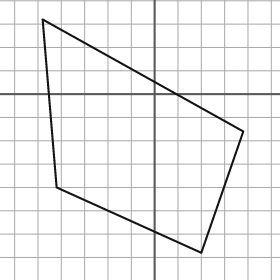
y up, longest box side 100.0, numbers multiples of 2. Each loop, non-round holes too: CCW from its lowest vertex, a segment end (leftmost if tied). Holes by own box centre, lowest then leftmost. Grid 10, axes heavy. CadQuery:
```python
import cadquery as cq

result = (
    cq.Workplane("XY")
    .moveTo(20.0, -68.0)
    .lineTo(38.0, -16.0)
    .lineTo(-48.0, 32.0)
    .lineTo(-42.0, -40.0)
    .close()
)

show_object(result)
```